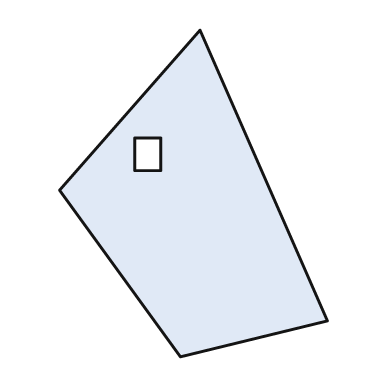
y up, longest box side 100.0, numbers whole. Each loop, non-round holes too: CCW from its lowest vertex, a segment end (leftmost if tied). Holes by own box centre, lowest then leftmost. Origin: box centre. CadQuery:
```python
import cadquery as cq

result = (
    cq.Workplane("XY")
    .moveTo(-4.0, -50.0)
    .lineTo(41.0, -39.0)
    .lineTo(2.0, 50.0)
    .lineTo(-41.0, 1.0)
    .close()
    .moveTo(-18.0, 7.0)
    .lineTo(-10.0, 7.0)
    .lineTo(-10.0, 17.0)
    .lineTo(-18.0, 17.0)
    .close()
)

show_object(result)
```